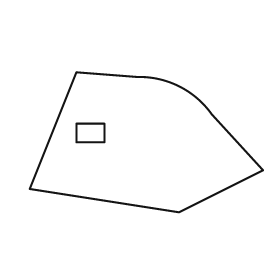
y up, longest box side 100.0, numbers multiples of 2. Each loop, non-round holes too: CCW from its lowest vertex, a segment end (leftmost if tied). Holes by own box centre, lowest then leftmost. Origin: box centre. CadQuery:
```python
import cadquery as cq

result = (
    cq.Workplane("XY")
    .moveTo(14.0, -30.0)
    .lineTo(50.0, -12.0)
    .lineTo(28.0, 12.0)
    .threePointArc((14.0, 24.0), (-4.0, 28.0))
    .lineTo(-30.0, 30.0)
    .lineTo(-50.0, -20.0)
    .close()
    .moveTo(-30.0, 0.0)
    .lineTo(-18.0, 0.0)
    .lineTo(-18.0, 8.0)
    .lineTo(-30.0, 8.0)
    .close()
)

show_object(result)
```